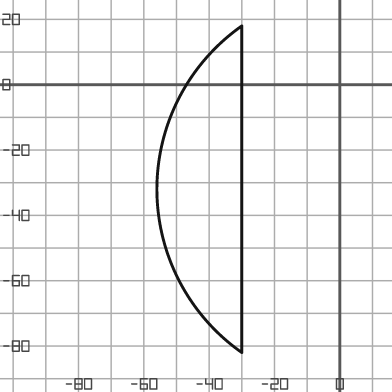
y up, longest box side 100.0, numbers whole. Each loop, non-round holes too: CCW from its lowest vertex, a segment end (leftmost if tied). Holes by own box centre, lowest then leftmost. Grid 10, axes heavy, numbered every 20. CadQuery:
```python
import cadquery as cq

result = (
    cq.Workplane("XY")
    .moveTo(-30.0, -82.0)
    .lineTo(-30.0, 18.0)
    .threePointArc((-56.0, -32.0), (-30.0, -82.0))
    .close()
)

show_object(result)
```